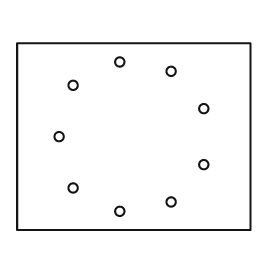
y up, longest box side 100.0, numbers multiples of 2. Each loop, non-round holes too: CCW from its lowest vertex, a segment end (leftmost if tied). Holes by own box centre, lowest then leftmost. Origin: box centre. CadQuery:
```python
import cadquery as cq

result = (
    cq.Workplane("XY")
    .moveTo(-50.0, -40.0)
    .lineTo(50.0, -40.0)
    .lineTo(50.0, 40.0)
    .lineTo(-50.0, 40.0)
    .close()
    .moveTo(-6.0, -32.0)
    .circle(2.0)
    .moveTo(16.0, -28.0)
    .circle(2.0)
    .moveTo(-26.0, -22.0)
    .circle(2.0)
    .moveTo(30.0, -12.0)
    .circle(2.0)
    .moveTo(-32.0, 0.0)
    .circle(2.0)
    .moveTo(30.0, 12.0)
    .circle(2.0)
    .moveTo(-26.0, 22.0)
    .circle(2.0)
    .moveTo(16.0, 28.0)
    .circle(2.0)
    .moveTo(-6.0, 32.0)
    .circle(2.0)
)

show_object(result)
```